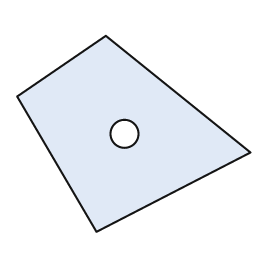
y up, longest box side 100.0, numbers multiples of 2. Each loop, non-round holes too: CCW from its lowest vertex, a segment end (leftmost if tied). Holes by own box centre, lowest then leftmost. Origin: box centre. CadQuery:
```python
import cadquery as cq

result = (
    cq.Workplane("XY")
    .moveTo(-16.0, -42.0)
    .lineTo(50.0, -8.0)
    .lineTo(-12.0, 42.0)
    .lineTo(-50.0, 16.0)
    .close()
    .moveTo(-4.0, 0.0)
    .circle(6.0)
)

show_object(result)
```